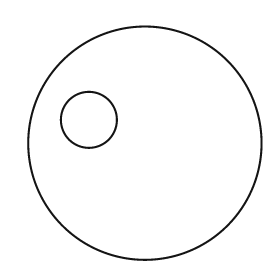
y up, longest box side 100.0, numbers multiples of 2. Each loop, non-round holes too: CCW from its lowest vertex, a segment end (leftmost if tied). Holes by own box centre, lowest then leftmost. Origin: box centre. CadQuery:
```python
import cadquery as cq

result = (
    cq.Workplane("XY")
    .moveTo(0.0, 0.0)
    .circle(50.0)
    .moveTo(-24.0, 10.0)
    .circle(12.0)
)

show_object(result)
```